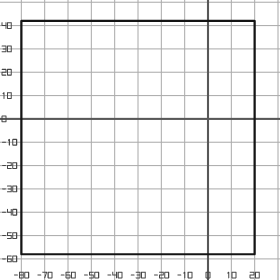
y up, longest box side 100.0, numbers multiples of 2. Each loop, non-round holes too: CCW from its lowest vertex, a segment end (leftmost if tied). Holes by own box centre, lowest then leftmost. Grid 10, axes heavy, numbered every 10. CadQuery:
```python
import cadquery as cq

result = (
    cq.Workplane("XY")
    .moveTo(-80.0, -58.0)
    .lineTo(20.0, -58.0)
    .lineTo(20.0, 42.0)
    .lineTo(-80.0, 42.0)
    .close()
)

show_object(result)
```